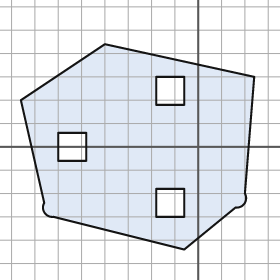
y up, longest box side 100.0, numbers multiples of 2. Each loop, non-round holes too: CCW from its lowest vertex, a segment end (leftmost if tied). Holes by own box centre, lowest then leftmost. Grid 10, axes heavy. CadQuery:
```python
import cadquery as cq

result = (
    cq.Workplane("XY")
    .moveTo(-6.0, -44.0)
    .lineTo(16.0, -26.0)
    .threePointArc((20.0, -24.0), (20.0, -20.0))
    .lineTo(24.0, 30.0)
    .lineTo(-40.0, 44.0)
    .lineTo(-76.0, 20.0)
    .lineTo(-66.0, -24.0)
    .threePointArc((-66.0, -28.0), (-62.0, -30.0))
    .close()
    .moveTo(-18.0, -30.0)
    .lineTo(-6.0, -30.0)
    .lineTo(-6.0, -18.0)
    .lineTo(-18.0, -18.0)
    .close()
    .moveTo(-60.0, -6.0)
    .lineTo(-48.0, -6.0)
    .lineTo(-48.0, 6.0)
    .lineTo(-60.0, 6.0)
    .close()
    .moveTo(-18.0, 18.0)
    .lineTo(-6.0, 18.0)
    .lineTo(-6.0, 30.0)
    .lineTo(-18.0, 30.0)
    .close()
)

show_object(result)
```